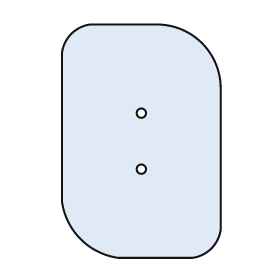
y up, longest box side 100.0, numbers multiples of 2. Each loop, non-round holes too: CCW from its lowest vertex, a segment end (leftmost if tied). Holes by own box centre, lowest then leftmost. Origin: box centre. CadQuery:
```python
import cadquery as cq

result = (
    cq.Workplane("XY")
    .moveTo(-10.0, -50.0)
    .lineTo(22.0, -50.0)
    .threePointArc((30.0, -46.0), (34.0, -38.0))
    .lineTo(34.0, 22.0)
    .threePointArc((26.0, 42.0), (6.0, 50.0))
    .lineTo(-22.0, 50.0)
    .threePointArc((-30.0, 46.0), (-34.0, 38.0))
    .lineTo(-34.0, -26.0)
    .threePointArc((-26.0, -42.0), (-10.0, -50.0))
    .close()
    .moveTo(0.0, -12.0)
    .circle(2.0)
    .moveTo(0.0, 12.0)
    .circle(2.0)
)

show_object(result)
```